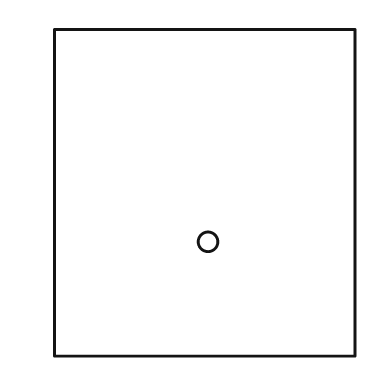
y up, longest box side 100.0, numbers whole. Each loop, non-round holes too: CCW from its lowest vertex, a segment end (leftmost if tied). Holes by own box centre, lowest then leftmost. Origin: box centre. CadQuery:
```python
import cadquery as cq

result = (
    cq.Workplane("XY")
    .moveTo(-46.0, -50.0)
    .lineTo(46.0, -50.0)
    .lineTo(46.0, 50.0)
    .lineTo(-46.0, 50.0)
    .close()
    .moveTo(1.0, -15.0)
    .circle(3.0)
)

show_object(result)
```